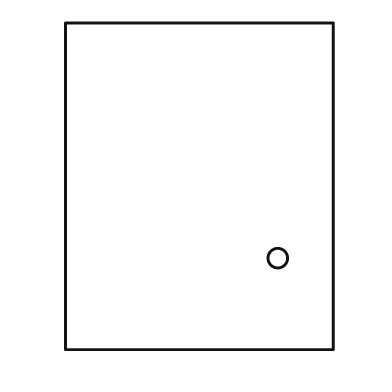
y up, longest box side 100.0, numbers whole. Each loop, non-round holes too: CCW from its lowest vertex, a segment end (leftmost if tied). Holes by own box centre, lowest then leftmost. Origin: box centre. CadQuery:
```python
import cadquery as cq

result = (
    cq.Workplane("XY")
    .moveTo(-41.0, -50.0)
    .lineTo(41.0, -50.0)
    .lineTo(41.0, 50.0)
    .lineTo(-41.0, 50.0)
    .close()
    .moveTo(24.0, -22.0)
    .circle(3.0)
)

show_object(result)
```